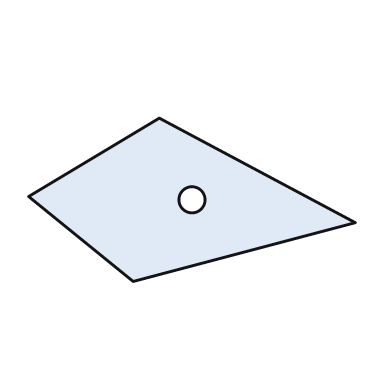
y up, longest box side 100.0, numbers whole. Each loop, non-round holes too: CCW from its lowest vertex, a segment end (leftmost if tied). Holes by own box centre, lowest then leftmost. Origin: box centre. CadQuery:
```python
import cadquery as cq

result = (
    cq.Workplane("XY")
    .moveTo(-18.0, -25.0)
    .lineTo(50.0, -7.0)
    .lineTo(-10.0, 25.0)
    .lineTo(-50.0, 1.0)
    .close()
    .moveTo(0.0, 0.0)
    .circle(4.0)
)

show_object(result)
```